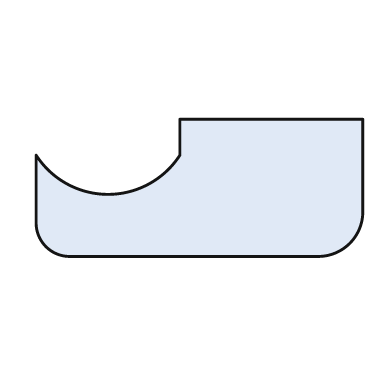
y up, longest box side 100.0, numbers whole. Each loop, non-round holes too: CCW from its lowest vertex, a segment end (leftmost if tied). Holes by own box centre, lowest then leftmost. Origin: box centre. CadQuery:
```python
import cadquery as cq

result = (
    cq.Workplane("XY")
    .moveTo(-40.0, -21.0)
    .lineTo(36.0, -21.0)
    .threePointArc((46.0, -17.0), (50.0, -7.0))
    .lineTo(50.0, 21.0)
    .lineTo(-6.0, 21.0)
    .lineTo(-6.0, 10.0)
    .threePointArc((-28.0, -2.0), (-50.0, 10.0))
    .lineTo(-50.0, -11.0)
    .threePointArc((-47.0, -18.0), (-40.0, -21.0))
    .close()
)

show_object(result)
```